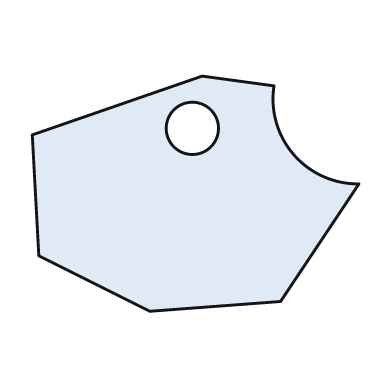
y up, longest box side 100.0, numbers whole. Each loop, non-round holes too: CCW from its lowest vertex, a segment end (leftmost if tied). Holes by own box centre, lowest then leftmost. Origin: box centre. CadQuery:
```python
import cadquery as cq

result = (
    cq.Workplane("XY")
    .moveTo(-14.0, -36.0)
    .lineTo(26.0, -33.0)
    .lineTo(50.0, 3.0)
    .threePointArc((30.0, 12.0), (24.0, 33.0))
    .lineTo(2.0, 36.0)
    .lineTo(-50.0, 18.0)
    .lineTo(-48.0, -19.0)
    .close()
    .moveTo(-1.0, 20.0)
    .circle(8.0)
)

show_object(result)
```